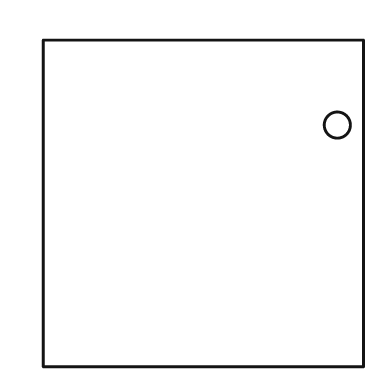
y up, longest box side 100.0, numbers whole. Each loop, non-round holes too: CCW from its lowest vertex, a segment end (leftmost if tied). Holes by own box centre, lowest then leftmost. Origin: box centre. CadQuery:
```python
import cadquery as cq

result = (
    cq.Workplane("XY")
    .moveTo(-49.0, -50.0)
    .lineTo(49.0, -50.0)
    .lineTo(49.0, 50.0)
    .lineTo(-49.0, 50.0)
    .close()
    .moveTo(41.0, 24.0)
    .circle(4.0)
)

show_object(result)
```